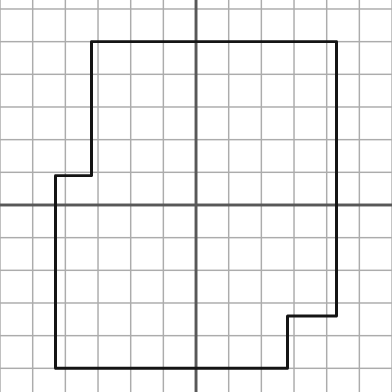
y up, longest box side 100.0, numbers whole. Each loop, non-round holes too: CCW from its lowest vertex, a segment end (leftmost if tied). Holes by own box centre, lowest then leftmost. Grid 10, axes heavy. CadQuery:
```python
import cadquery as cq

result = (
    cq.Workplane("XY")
    .moveTo(-43.0, -50.0)
    .lineTo(28.0, -50.0)
    .lineTo(28.0, -34.0)
    .lineTo(43.0, -34.0)
    .lineTo(43.0, 50.0)
    .lineTo(-32.0, 50.0)
    .lineTo(-32.0, 9.0)
    .lineTo(-43.0, 9.0)
    .close()
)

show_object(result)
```